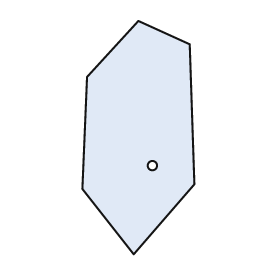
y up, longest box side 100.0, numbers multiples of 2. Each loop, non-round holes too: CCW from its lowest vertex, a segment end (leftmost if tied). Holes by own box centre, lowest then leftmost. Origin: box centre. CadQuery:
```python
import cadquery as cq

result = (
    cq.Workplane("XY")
    .moveTo(-2.0, -50.0)
    .lineTo(24.0, -20.0)
    .lineTo(22.0, 40.0)
    .lineTo(0.0, 50.0)
    .lineTo(-22.0, 26.0)
    .lineTo(-24.0, -22.0)
    .close()
    .moveTo(6.0, -12.0)
    .circle(2.0)
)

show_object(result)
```